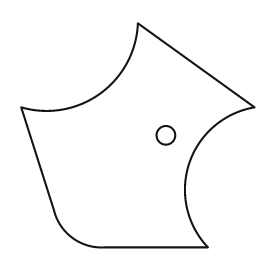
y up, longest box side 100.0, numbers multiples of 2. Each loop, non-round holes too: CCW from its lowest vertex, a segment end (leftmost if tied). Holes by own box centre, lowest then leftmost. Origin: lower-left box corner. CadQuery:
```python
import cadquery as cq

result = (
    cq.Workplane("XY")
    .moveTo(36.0, 0.0)
    .lineTo(80.0, 0.0)
    .threePointArc((72.0, 36.0), (100.0, 60.0))
    .lineTo(50.0, 96.0)
    .threePointArc((34.0, 66.0), (0.0, 60.0))
    .lineTo(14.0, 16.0)
    .threePointArc((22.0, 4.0), (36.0, 0.0))
    .close()
    .moveTo(62.0, 48.0)
    .circle(4.0)
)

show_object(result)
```